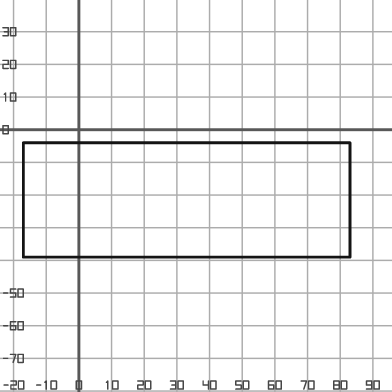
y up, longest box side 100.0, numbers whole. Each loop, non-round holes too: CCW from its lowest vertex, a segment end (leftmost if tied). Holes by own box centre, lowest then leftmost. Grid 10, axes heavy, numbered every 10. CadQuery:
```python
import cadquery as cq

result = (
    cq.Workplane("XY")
    .moveTo(-17.0, -39.0)
    .lineTo(83.0, -39.0)
    .lineTo(83.0, -4.0)
    .lineTo(-17.0, -4.0)
    .close()
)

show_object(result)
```